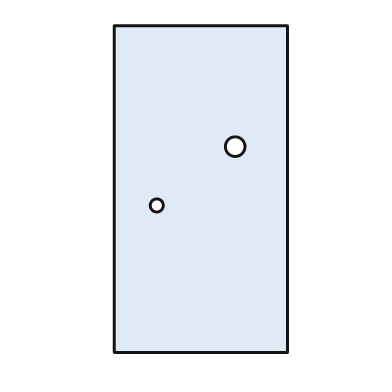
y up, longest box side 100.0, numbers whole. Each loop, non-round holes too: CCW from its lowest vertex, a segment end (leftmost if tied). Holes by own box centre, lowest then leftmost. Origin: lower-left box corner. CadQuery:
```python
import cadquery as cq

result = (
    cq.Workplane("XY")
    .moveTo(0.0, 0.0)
    .lineTo(53.0, 0.0)
    .lineTo(53.0, 100.0)
    .lineTo(0.0, 100.0)
    .close()
    .moveTo(13.0, 45.0)
    .circle(2.0)
    .moveTo(37.0, 63.0)
    .circle(3.0)
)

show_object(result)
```